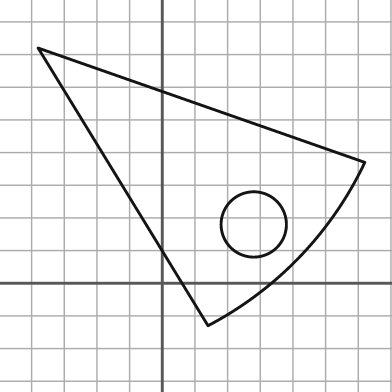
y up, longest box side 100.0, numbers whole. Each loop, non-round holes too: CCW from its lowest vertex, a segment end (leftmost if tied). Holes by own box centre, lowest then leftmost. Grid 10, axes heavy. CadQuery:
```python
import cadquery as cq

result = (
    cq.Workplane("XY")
    .moveTo(14.0, -13.0)
    .threePointArc((42.0, 8.0), (62.0, 37.0))
    .lineTo(-38.0, 72.0)
    .close()
    .moveTo(28.0, 18.0)
    .circle(10.0)
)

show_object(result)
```